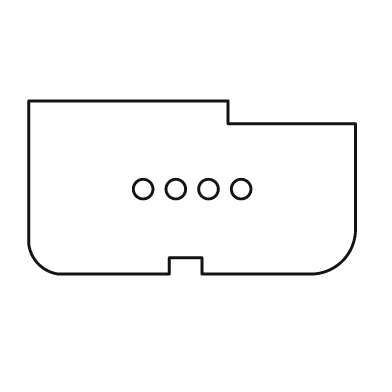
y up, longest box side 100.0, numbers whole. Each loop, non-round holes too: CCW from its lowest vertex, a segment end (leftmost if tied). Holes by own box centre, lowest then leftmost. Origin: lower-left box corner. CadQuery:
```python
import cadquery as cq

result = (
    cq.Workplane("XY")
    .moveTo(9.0, 0.0)
    .lineTo(43.0, 0.0)
    .lineTo(43.0, 5.0)
    .lineTo(53.0, 5.0)
    .lineTo(53.0, 0.0)
    .lineTo(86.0, 0.0)
    .threePointArc((96.0, 4.0), (100.0, 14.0))
    .lineTo(100.0, 46.0)
    .lineTo(61.0, 46.0)
    .lineTo(61.0, 53.0)
    .lineTo(0.0, 53.0)
    .lineTo(0.0, 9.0)
    .threePointArc((3.0, 3.0), (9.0, 0.0))
    .close()
    .moveTo(35.0, 26.0)
    .circle(3.0)
    .moveTo(45.0, 26.0)
    .circle(3.0)
    .moveTo(55.0, 26.0)
    .circle(3.0)
    .moveTo(65.0, 26.0)
    .circle(3.0)
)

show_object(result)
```